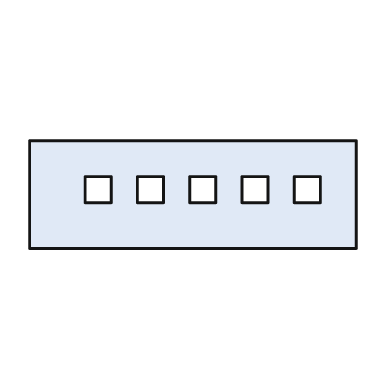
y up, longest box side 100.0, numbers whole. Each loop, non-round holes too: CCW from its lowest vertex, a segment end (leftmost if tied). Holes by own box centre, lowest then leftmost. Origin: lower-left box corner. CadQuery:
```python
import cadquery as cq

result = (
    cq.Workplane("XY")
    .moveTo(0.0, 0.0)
    .lineTo(100.0, 0.0)
    .lineTo(100.0, 33.0)
    .lineTo(0.0, 33.0)
    .close()
    .moveTo(17.0, 14.0)
    .lineTo(25.0, 14.0)
    .lineTo(25.0, 22.0)
    .lineTo(17.0, 22.0)
    .close()
    .moveTo(33.0, 14.0)
    .lineTo(41.0, 14.0)
    .lineTo(41.0, 22.0)
    .lineTo(33.0, 22.0)
    .close()
    .moveTo(49.0, 14.0)
    .lineTo(57.0, 14.0)
    .lineTo(57.0, 22.0)
    .lineTo(49.0, 22.0)
    .close()
    .moveTo(65.0, 14.0)
    .lineTo(73.0, 14.0)
    .lineTo(73.0, 22.0)
    .lineTo(65.0, 22.0)
    .close()
    .moveTo(81.0, 14.0)
    .lineTo(89.0, 14.0)
    .lineTo(89.0, 22.0)
    .lineTo(81.0, 22.0)
    .close()
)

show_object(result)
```